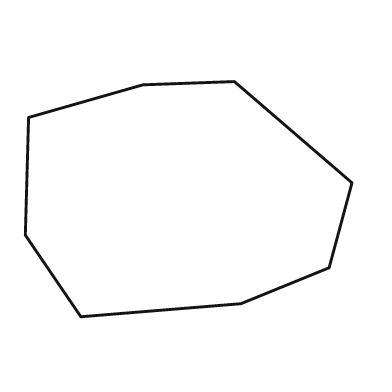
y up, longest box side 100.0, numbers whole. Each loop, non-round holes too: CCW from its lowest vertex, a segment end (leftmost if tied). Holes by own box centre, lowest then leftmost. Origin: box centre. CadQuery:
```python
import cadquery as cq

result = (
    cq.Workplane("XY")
    .moveTo(-33.0, -36.0)
    .lineTo(16.0, -32.0)
    .lineTo(43.0, -21.0)
    .lineTo(50.0, 5.0)
    .lineTo(14.0, 36.0)
    .lineTo(-14.0, 35.0)
    .lineTo(-49.0, 25.0)
    .lineTo(-50.0, -11.0)
    .close()
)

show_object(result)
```